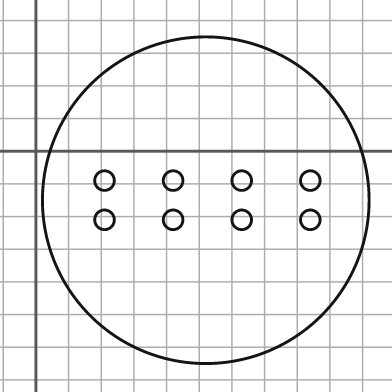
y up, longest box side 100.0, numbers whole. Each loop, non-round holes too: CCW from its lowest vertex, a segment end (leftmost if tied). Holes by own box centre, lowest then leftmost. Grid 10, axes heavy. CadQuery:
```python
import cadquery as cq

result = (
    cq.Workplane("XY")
    .moveTo(52.0, -15.0)
    .circle(50.0)
    .moveTo(21.0, -21.0)
    .circle(3.0)
    .moveTo(42.0, -21.0)
    .circle(3.0)
    .moveTo(63.0, -21.0)
    .circle(3.0)
    .moveTo(84.0, -21.0)
    .circle(3.0)
    .moveTo(21.0, -9.0)
    .circle(3.0)
    .moveTo(42.0, -9.0)
    .circle(3.0)
    .moveTo(63.0, -9.0)
    .circle(3.0)
    .moveTo(84.0, -9.0)
    .circle(3.0)
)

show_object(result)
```